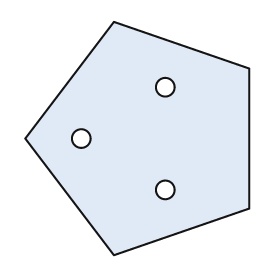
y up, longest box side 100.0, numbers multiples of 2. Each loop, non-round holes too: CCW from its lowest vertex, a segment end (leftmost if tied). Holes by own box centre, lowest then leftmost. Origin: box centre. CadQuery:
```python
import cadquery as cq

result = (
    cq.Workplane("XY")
    .moveTo(-10.0, -50.0)
    .lineTo(48.0, -30.0)
    .lineTo(48.0, 30.0)
    .lineTo(-10.0, 50.0)
    .lineTo(-48.0, 0.0)
    .close()
    .moveTo(12.0, -22.0)
    .circle(4.0)
    .moveTo(-24.0, 0.0)
    .circle(4.0)
    .moveTo(12.0, 22.0)
    .circle(4.0)
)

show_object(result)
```